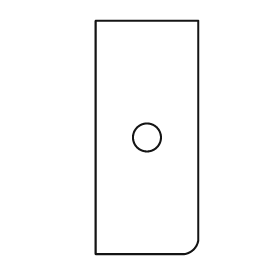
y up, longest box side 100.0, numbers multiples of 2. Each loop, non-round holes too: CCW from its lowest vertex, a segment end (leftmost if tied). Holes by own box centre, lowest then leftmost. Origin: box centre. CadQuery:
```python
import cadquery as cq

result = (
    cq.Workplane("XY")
    .moveTo(-22.0, -50.0)
    .lineTo(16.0, -50.0)
    .threePointArc((20.0, -48.0), (22.0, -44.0))
    .lineTo(22.0, 50.0)
    .lineTo(-22.0, 50.0)
    .close()
    .moveTo(0.0, 0.0)
    .circle(6.0)
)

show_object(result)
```